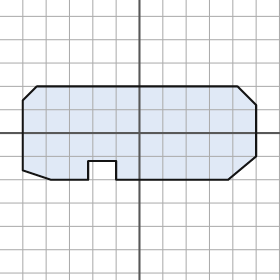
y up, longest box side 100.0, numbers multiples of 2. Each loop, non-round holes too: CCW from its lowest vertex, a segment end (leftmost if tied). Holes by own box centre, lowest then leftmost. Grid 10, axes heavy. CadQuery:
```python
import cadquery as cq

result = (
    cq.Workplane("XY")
    .moveTo(-38.0, -20.0)
    .lineTo(-22.0, -20.0)
    .lineTo(-22.0, -12.0)
    .lineTo(-10.0, -12.0)
    .lineTo(-10.0, -20.0)
    .lineTo(38.0, -20.0)
    .lineTo(50.0, -10.0)
    .lineTo(50.0, 12.0)
    .lineTo(42.0, 20.0)
    .lineTo(-44.0, 20.0)
    .lineTo(-50.0, 14.0)
    .lineTo(-50.0, -16.0)
    .close()
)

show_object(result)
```